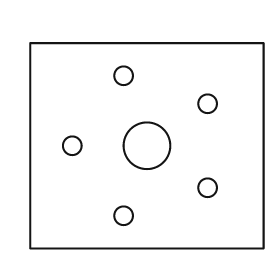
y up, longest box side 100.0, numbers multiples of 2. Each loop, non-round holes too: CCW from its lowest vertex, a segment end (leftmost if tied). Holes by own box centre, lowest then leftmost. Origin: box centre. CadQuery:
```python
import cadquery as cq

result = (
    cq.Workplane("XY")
    .moveTo(-50.0, -44.0)
    .lineTo(50.0, -44.0)
    .lineTo(50.0, 44.0)
    .lineTo(-50.0, 44.0)
    .close()
    .moveTo(-10.0, -30.0)
    .circle(4.0)
    .moveTo(26.0, -18.0)
    .circle(4.0)
    .moveTo(-32.0, 0.0)
    .circle(4.0)
    .moveTo(0.0, 0.0)
    .circle(10.0)
    .moveTo(26.0, 18.0)
    .circle(4.0)
    .moveTo(-10.0, 30.0)
    .circle(4.0)
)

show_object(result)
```